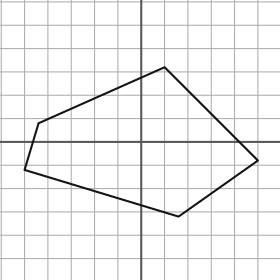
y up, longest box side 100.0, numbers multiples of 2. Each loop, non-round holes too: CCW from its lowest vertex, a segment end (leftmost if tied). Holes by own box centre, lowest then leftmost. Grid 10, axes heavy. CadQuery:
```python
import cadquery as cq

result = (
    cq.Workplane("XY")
    .moveTo(16.0, -32.0)
    .lineTo(50.0, -8.0)
    .lineTo(10.0, 32.0)
    .lineTo(-44.0, 8.0)
    .lineTo(-50.0, -12.0)
    .close()
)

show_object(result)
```